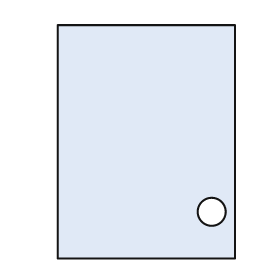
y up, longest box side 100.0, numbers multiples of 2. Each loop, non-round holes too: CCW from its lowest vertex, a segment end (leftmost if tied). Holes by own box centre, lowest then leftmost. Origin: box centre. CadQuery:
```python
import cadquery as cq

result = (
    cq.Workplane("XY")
    .moveTo(-38.0, -50.0)
    .lineTo(38.0, -50.0)
    .lineTo(38.0, 50.0)
    .lineTo(-38.0, 50.0)
    .close()
    .moveTo(28.0, -30.0)
    .circle(6.0)
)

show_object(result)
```